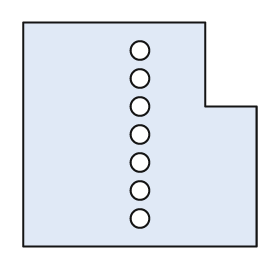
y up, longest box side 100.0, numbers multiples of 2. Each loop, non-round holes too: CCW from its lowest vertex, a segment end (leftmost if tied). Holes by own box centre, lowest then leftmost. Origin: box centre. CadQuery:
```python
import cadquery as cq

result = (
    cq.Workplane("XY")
    .moveTo(-50.0, -48.0)
    .lineTo(50.0, -48.0)
    .lineTo(50.0, 12.0)
    .lineTo(28.0, 12.0)
    .lineTo(28.0, 48.0)
    .lineTo(-50.0, 48.0)
    .close()
    .moveTo(0.0, -36.0)
    .circle(4.0)
    .moveTo(0.0, -24.0)
    .circle(4.0)
    .moveTo(0.0, -12.0)
    .circle(4.0)
    .moveTo(0.0, 0.0)
    .circle(4.0)
    .moveTo(0.0, 12.0)
    .circle(4.0)
    .moveTo(0.0, 24.0)
    .circle(4.0)
    .moveTo(0.0, 36.0)
    .circle(4.0)
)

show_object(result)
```